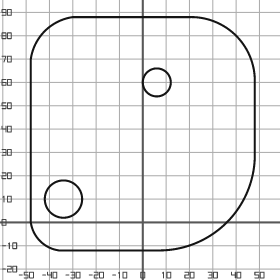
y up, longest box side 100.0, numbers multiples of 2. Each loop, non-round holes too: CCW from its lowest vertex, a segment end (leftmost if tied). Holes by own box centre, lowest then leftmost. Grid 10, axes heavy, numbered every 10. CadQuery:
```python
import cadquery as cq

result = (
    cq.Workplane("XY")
    .moveTo(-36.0, -12.0)
    .lineTo(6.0, -12.0)
    .threePointArc((36.0, 0.0), (48.0, 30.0))
    .lineTo(48.0, 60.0)
    .threePointArc((40.0, 80.0), (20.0, 88.0))
    .lineTo(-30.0, 88.0)
    .threePointArc((-42.0, 82.0), (-48.0, 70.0))
    .lineTo(-48.0, 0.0)
    .threePointArc((-44.0, -8.0), (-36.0, -12.0))
    .close()
    .moveTo(-34.0, 10.0)
    .circle(8.0)
    .moveTo(6.0, 60.0)
    .circle(6.0)
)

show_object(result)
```